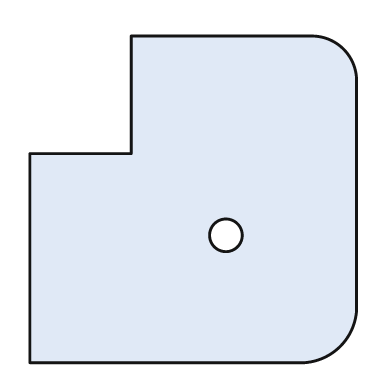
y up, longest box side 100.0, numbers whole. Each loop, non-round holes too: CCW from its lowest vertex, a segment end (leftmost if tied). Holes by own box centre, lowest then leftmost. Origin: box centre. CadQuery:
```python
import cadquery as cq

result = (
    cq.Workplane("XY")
    .moveTo(-50.0, -50.0)
    .lineTo(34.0, -50.0)
    .threePointArc((45.0, -45.0), (50.0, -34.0))
    .lineTo(50.0, 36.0)
    .threePointArc((46.0, 46.0), (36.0, 50.0))
    .lineTo(-19.0, 50.0)
    .lineTo(-19.0, 14.0)
    .lineTo(-50.0, 14.0)
    .close()
    .moveTo(10.0, -11.0)
    .circle(5.0)
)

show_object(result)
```